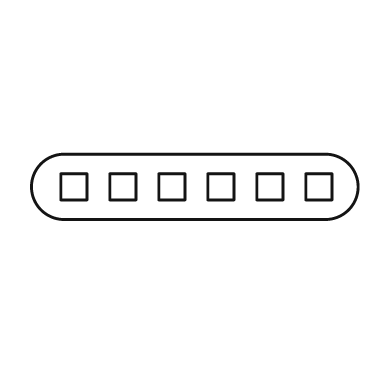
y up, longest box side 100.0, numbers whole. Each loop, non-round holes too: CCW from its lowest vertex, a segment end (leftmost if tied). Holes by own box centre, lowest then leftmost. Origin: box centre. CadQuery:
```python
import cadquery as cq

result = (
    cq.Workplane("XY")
    .moveTo(-40.0, -10.0)
    .lineTo(40.0, -10.0)
    .threePointArc((50.0, 0.0), (40.0, 10.0))
    .lineTo(-40.0, 10.0)
    .threePointArc((-50.0, 0.0), (-40.0, -10.0))
    .close()
    .moveTo(-41.0, -4.0)
    .lineTo(-33.0, -4.0)
    .lineTo(-33.0, 4.0)
    .lineTo(-41.0, 4.0)
    .close()
    .moveTo(-26.0, -4.0)
    .lineTo(-18.0, -4.0)
    .lineTo(-18.0, 4.0)
    .lineTo(-26.0, 4.0)
    .close()
    .moveTo(-11.0, -4.0)
    .lineTo(-3.0, -4.0)
    .lineTo(-3.0, 4.0)
    .lineTo(-11.0, 4.0)
    .close()
    .moveTo(4.0, -4.0)
    .lineTo(12.0, -4.0)
    .lineTo(12.0, 4.0)
    .lineTo(4.0, 4.0)
    .close()
    .moveTo(19.0, -4.0)
    .lineTo(27.0, -4.0)
    .lineTo(27.0, 4.0)
    .lineTo(19.0, 4.0)
    .close()
    .moveTo(34.0, -4.0)
    .lineTo(42.0, -4.0)
    .lineTo(42.0, 4.0)
    .lineTo(34.0, 4.0)
    .close()
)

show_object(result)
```